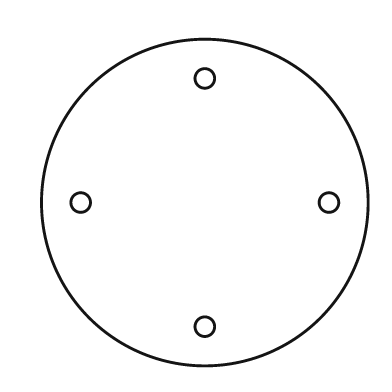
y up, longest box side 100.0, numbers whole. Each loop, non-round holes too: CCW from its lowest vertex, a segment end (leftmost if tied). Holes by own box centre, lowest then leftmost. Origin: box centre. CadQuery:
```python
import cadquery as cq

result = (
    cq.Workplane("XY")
    .moveTo(0.0, 0.0)
    .circle(50.0)
    .moveTo(0.0, -38.0)
    .circle(3.0)
    .moveTo(-38.0, 0.0)
    .circle(3.0)
    .moveTo(38.0, 0.0)
    .circle(3.0)
    .moveTo(0.0, 38.0)
    .circle(3.0)
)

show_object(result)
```